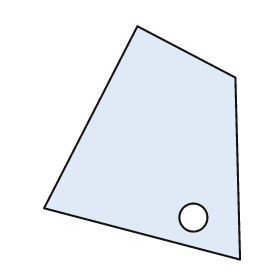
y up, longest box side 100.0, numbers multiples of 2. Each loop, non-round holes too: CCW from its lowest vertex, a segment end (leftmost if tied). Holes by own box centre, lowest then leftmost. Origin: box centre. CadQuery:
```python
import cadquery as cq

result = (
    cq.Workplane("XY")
    .moveTo(42.0, -50.0)
    .lineTo(40.0, 28.0)
    .lineTo(-2.0, 50.0)
    .lineTo(-42.0, -28.0)
    .close()
    .moveTo(22.0, -32.0)
    .circle(6.0)
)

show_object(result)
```